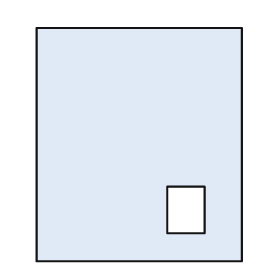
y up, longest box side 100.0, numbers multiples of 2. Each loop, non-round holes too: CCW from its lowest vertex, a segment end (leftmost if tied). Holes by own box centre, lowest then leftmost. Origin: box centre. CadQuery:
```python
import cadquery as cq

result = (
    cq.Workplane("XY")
    .moveTo(-44.0, -50.0)
    .lineTo(44.0, -50.0)
    .lineTo(44.0, 50.0)
    .lineTo(-44.0, 50.0)
    .close()
    .moveTo(12.0, -38.0)
    .lineTo(28.0, -38.0)
    .lineTo(28.0, -18.0)
    .lineTo(12.0, -18.0)
    .close()
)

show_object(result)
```